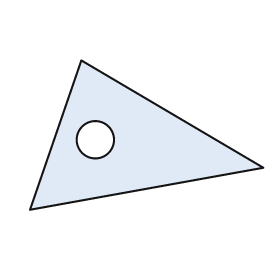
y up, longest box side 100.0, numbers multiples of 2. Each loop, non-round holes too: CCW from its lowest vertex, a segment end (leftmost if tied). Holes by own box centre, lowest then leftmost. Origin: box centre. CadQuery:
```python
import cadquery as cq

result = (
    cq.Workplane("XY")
    .moveTo(-50.0, -32.0)
    .lineTo(50.0, -14.0)
    .lineTo(-28.0, 32.0)
    .close()
    .moveTo(-22.0, -2.0)
    .circle(8.0)
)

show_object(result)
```